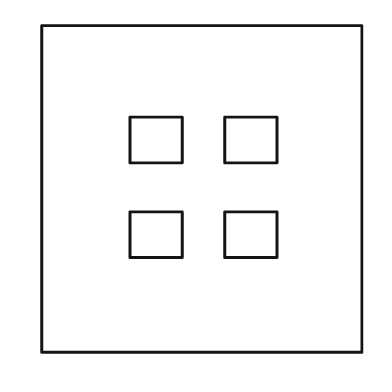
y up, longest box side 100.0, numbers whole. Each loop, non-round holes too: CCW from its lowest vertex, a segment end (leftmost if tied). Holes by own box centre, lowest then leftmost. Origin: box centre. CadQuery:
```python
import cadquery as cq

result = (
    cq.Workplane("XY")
    .moveTo(-49.0, -50.0)
    .lineTo(49.0, -50.0)
    .lineTo(49.0, 50.0)
    .lineTo(-49.0, 50.0)
    .close()
    .moveTo(-22.0, -21.0)
    .lineTo(-6.0, -21.0)
    .lineTo(-6.0, -7.0)
    .lineTo(-22.0, -7.0)
    .close()
    .moveTo(7.0, -21.0)
    .lineTo(23.0, -21.0)
    .lineTo(23.0, -7.0)
    .lineTo(7.0, -7.0)
    .close()
    .moveTo(-22.0, 8.0)
    .lineTo(-6.0, 8.0)
    .lineTo(-6.0, 22.0)
    .lineTo(-22.0, 22.0)
    .close()
    .moveTo(7.0, 8.0)
    .lineTo(23.0, 8.0)
    .lineTo(23.0, 22.0)
    .lineTo(7.0, 22.0)
    .close()
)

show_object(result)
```